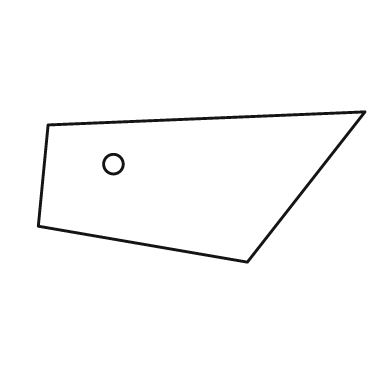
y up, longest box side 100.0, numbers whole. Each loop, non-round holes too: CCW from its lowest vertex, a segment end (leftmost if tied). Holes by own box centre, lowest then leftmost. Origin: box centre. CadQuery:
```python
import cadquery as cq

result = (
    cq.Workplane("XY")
    .moveTo(14.0, -23.0)
    .lineTo(50.0, 23.0)
    .lineTo(-47.0, 19.0)
    .lineTo(-50.0, -12.0)
    .close()
    .moveTo(-27.0, 7.0)
    .circle(3.0)
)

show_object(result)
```